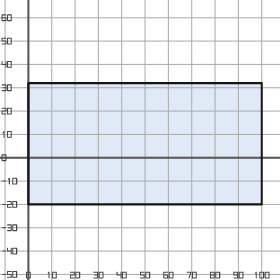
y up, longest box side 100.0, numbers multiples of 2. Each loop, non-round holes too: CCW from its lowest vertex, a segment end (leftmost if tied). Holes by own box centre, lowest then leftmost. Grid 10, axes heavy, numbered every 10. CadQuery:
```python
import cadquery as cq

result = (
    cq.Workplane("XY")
    .moveTo(0.0, -20.0)
    .lineTo(100.0, -20.0)
    .lineTo(100.0, 32.0)
    .lineTo(0.0, 32.0)
    .close()
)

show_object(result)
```